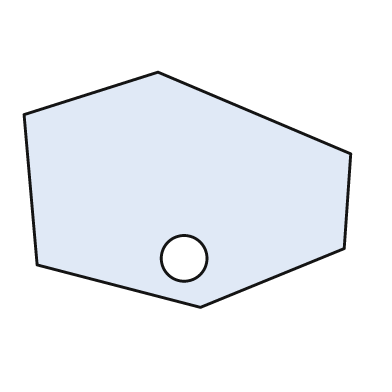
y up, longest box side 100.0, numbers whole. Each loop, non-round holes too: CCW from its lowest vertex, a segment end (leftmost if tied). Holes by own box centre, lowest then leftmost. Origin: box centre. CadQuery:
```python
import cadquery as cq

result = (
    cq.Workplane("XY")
    .moveTo(4.0, -36.0)
    .lineTo(48.0, -18.0)
    .lineTo(50.0, 11.0)
    .lineTo(-9.0, 36.0)
    .lineTo(-50.0, 23.0)
    .lineTo(-46.0, -23.0)
    .close()
    .moveTo(-1.0, -21.0)
    .circle(7.0)
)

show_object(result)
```